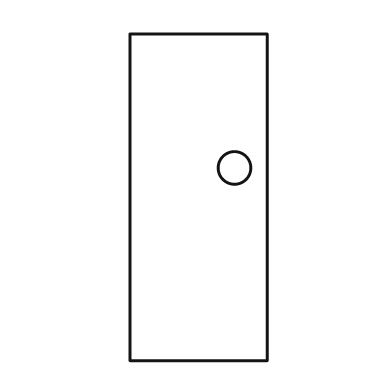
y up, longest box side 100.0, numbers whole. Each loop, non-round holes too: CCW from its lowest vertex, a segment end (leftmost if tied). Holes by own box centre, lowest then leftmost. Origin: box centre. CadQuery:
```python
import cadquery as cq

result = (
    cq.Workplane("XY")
    .moveTo(-21.0, -50.0)
    .lineTo(21.0, -50.0)
    .lineTo(21.0, 50.0)
    .lineTo(-21.0, 50.0)
    .close()
    .moveTo(11.0, 9.0)
    .circle(5.0)
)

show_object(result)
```